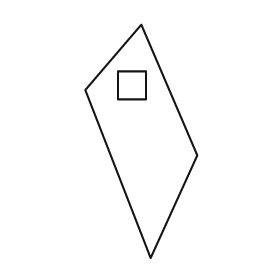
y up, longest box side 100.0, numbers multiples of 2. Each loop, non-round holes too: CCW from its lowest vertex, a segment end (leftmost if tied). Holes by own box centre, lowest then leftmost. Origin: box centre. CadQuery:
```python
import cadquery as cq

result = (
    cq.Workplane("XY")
    .moveTo(4.0, -50.0)
    .lineTo(24.0, -6.0)
    .lineTo(0.0, 50.0)
    .lineTo(-24.0, 22.0)
    .close()
    .moveTo(-10.0, 18.0)
    .lineTo(2.0, 18.0)
    .lineTo(2.0, 30.0)
    .lineTo(-10.0, 30.0)
    .close()
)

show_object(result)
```